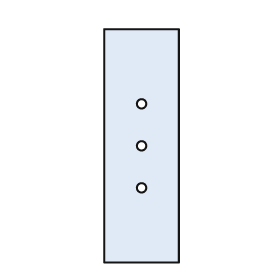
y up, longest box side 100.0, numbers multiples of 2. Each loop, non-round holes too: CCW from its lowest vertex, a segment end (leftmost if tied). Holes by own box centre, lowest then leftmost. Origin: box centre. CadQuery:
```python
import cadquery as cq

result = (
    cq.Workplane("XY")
    .moveTo(-16.0, -50.0)
    .lineTo(16.0, -50.0)
    .lineTo(16.0, 50.0)
    .lineTo(-16.0, 50.0)
    .close()
    .moveTo(0.0, -18.0)
    .circle(2.0)
    .moveTo(0.0, 0.0)
    .circle(2.0)
    .moveTo(0.0, 18.0)
    .circle(2.0)
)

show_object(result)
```